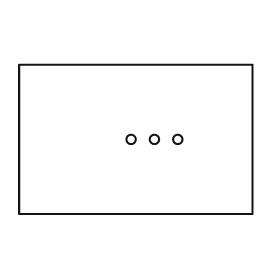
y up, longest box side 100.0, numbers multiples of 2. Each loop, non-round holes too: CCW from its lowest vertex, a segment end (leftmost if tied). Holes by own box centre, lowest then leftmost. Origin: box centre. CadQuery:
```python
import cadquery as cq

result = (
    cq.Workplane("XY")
    .moveTo(-50.0, -32.0)
    .lineTo(50.0, -32.0)
    .lineTo(50.0, 32.0)
    .lineTo(-50.0, 32.0)
    .close()
    .moveTo(-2.0, 0.0)
    .circle(2.0)
    .moveTo(8.0, 0.0)
    .circle(2.0)
    .moveTo(18.0, 0.0)
    .circle(2.0)
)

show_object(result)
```